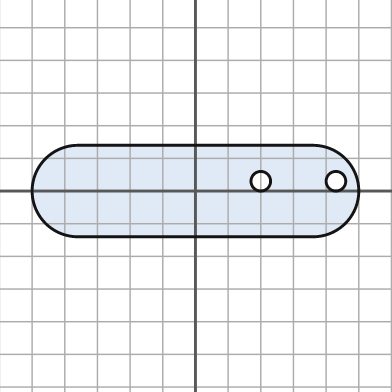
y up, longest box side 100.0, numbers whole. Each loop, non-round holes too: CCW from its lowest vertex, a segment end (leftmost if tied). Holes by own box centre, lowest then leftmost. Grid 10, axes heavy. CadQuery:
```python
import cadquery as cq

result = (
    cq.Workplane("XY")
    .moveTo(-36.0, -14.0)
    .lineTo(36.0, -14.0)
    .threePointArc((50.0, 0.0), (36.0, 14.0))
    .lineTo(-36.0, 14.0)
    .threePointArc((-50.0, 0.0), (-36.0, -14.0))
    .close()
    .moveTo(20.0, 3.0)
    .circle(3.0)
    .moveTo(43.0, 3.0)
    .circle(3.0)
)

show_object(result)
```